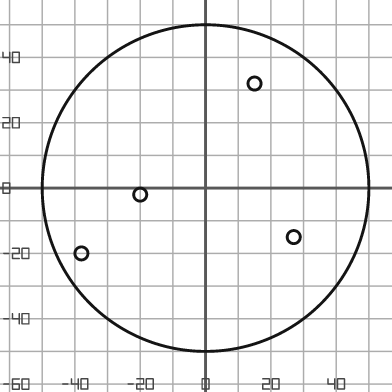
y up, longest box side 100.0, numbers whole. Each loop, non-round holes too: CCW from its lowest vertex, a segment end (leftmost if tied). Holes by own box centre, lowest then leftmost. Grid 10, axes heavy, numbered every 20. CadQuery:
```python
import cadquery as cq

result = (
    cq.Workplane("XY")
    .moveTo(0.0, 0.0)
    .circle(50.0)
    .moveTo(-38.0, -20.0)
    .circle(2.0)
    .moveTo(27.0, -15.0)
    .circle(2.0)
    .moveTo(-20.0, -2.0)
    .circle(2.0)
    .moveTo(15.0, 32.0)
    .circle(2.0)
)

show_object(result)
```